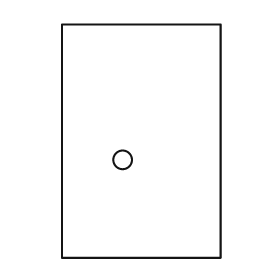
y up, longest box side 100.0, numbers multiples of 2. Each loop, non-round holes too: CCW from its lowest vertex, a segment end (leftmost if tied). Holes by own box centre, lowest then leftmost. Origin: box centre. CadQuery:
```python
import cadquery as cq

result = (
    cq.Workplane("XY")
    .moveTo(-34.0, -50.0)
    .lineTo(34.0, -50.0)
    .lineTo(34.0, 50.0)
    .lineTo(-34.0, 50.0)
    .close()
    .moveTo(-8.0, -8.0)
    .circle(4.0)
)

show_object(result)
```